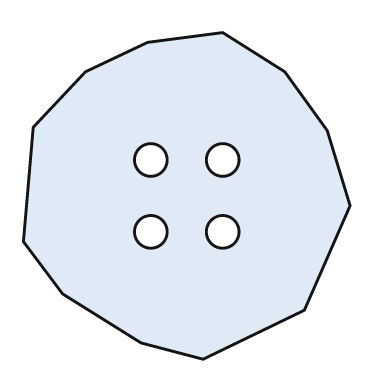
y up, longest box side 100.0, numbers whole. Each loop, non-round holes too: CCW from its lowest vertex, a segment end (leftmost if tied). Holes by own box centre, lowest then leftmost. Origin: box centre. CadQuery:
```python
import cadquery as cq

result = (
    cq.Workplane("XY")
    .moveTo(5.0, -50.0)
    .lineTo(36.0, -35.0)
    .lineTo(50.0, -3.0)
    .lineTo(43.0, 20.0)
    .lineTo(30.0, 38.0)
    .lineTo(11.0, 50.0)
    .lineTo(-12.0, 47.0)
    .lineTo(-31.0, 38.0)
    .lineTo(-47.0, 21.0)
    .lineTo(-50.0, -14.0)
    .lineTo(-38.0, -30.0)
    .lineTo(-14.0, -45.0)
    .close()
    .moveTo(-11.0, -11.0)
    .circle(5.0)
    .moveTo(11.0, -11.0)
    .circle(5.0)
    .moveTo(-11.0, 11.0)
    .circle(5.0)
    .moveTo(11.0, 11.0)
    .circle(5.0)
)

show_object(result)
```